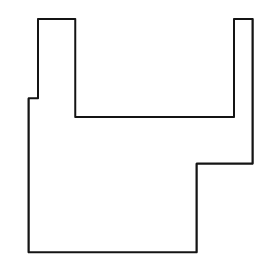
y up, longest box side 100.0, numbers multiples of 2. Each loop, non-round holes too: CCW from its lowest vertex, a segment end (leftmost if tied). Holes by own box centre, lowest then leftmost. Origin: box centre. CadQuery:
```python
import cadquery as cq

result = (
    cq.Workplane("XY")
    .moveTo(-48.0, -50.0)
    .lineTo(24.0, -50.0)
    .lineTo(24.0, -12.0)
    .lineTo(48.0, -12.0)
    .lineTo(48.0, 50.0)
    .lineTo(40.0, 50.0)
    .lineTo(40.0, 8.0)
    .lineTo(-28.0, 8.0)
    .lineTo(-28.0, 50.0)
    .lineTo(-44.0, 50.0)
    .lineTo(-44.0, 16.0)
    .lineTo(-48.0, 16.0)
    .close()
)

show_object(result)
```